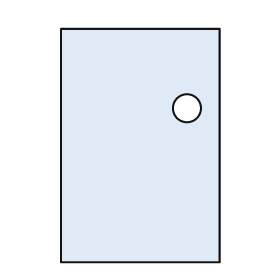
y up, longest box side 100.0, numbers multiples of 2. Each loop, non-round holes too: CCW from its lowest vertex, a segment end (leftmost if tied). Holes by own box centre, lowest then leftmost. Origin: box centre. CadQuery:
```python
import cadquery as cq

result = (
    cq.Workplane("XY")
    .moveTo(-34.0, -50.0)
    .lineTo(34.0, -50.0)
    .lineTo(34.0, 50.0)
    .lineTo(-34.0, 50.0)
    .close()
    .moveTo(20.0, 16.0)
    .circle(6.0)
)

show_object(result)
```